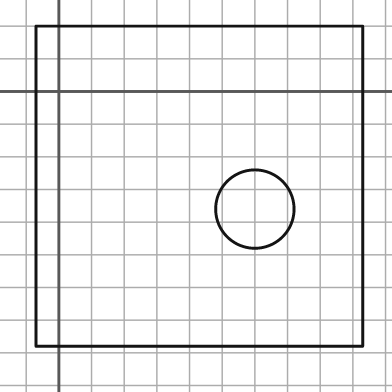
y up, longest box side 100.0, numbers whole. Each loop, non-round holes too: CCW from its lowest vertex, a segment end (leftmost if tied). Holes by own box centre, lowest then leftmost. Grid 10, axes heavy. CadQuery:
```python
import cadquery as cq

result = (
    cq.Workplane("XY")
    .moveTo(-7.0, -78.0)
    .lineTo(93.0, -78.0)
    .lineTo(93.0, 20.0)
    .lineTo(-7.0, 20.0)
    .close()
    .moveTo(60.0, -36.0)
    .circle(12.0)
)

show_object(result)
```